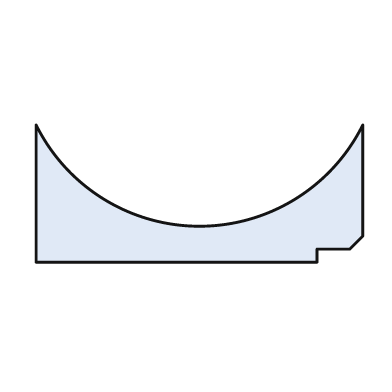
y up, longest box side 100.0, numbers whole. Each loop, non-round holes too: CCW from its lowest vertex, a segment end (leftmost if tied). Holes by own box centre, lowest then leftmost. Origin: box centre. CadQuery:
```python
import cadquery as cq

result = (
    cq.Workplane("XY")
    .moveTo(-50.0, -21.0)
    .lineTo(36.0, -21.0)
    .lineTo(36.0, -17.0)
    .lineTo(46.0, -17.0)
    .lineTo(50.0, -13.0)
    .lineTo(50.0, 21.0)
    .threePointArc((0.0, -10.0), (-50.0, 21.0))
    .close()
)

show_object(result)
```